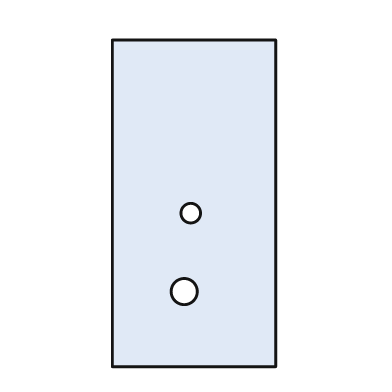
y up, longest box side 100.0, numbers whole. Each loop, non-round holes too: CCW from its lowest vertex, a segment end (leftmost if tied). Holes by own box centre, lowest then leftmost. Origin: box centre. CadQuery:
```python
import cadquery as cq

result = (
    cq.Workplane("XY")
    .moveTo(-25.0, -50.0)
    .lineTo(25.0, -50.0)
    .lineTo(25.0, 50.0)
    .lineTo(-25.0, 50.0)
    .close()
    .moveTo(-3.0, -27.0)
    .circle(4.0)
    .moveTo(-1.0, -3.0)
    .circle(3.0)
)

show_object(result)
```